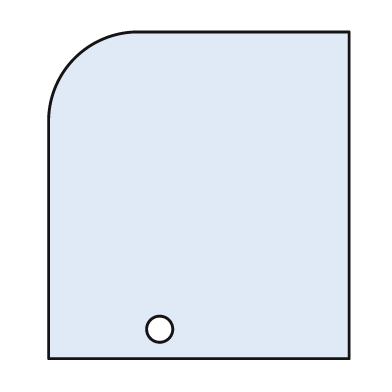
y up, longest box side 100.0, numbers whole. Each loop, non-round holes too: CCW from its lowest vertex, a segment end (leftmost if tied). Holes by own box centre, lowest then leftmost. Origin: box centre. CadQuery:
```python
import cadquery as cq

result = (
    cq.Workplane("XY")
    .moveTo(-46.0, -50.0)
    .lineTo(46.0, -50.0)
    .lineTo(46.0, 50.0)
    .lineTo(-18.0, 50.0)
    .threePointArc((-38.0, 42.0), (-46.0, 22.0))
    .close()
    .moveTo(-12.0, -41.0)
    .circle(4.0)
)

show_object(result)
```